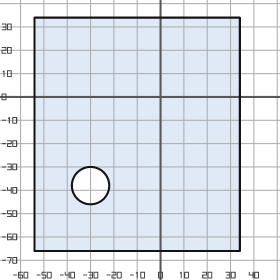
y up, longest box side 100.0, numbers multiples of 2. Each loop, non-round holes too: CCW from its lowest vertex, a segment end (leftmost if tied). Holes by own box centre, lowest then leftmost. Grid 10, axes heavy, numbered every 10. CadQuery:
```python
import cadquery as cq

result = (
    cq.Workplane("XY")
    .moveTo(-54.0, -66.0)
    .lineTo(34.0, -66.0)
    .lineTo(34.0, 34.0)
    .lineTo(-54.0, 34.0)
    .close()
    .moveTo(-30.0, -38.0)
    .circle(8.0)
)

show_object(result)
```